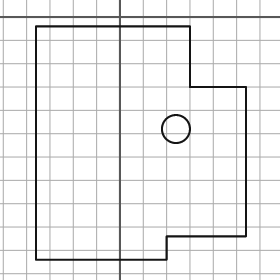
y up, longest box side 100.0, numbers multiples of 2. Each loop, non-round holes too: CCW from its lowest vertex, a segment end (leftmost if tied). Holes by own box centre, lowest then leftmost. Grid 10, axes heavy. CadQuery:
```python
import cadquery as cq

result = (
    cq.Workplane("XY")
    .moveTo(-36.0, -104.0)
    .lineTo(20.0, -104.0)
    .lineTo(20.0, -94.0)
    .lineTo(54.0, -94.0)
    .lineTo(54.0, -30.0)
    .lineTo(30.0, -30.0)
    .lineTo(30.0, -4.0)
    .lineTo(-36.0, -4.0)
    .close()
    .moveTo(24.0, -48.0)
    .circle(6.0)
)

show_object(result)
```